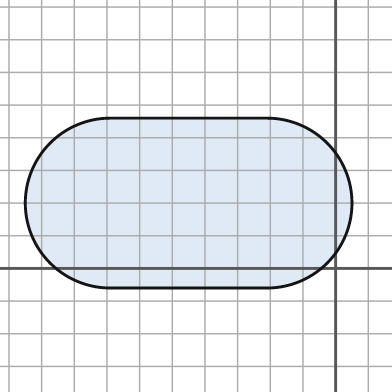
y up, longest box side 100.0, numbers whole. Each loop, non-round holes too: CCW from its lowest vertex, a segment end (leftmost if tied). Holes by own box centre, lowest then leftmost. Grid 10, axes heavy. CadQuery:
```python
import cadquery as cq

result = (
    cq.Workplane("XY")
    .moveTo(-69.0, -6.0)
    .lineTo(-21.0, -6.0)
    .threePointArc((5.0, 20.0), (-21.0, 46.0))
    .lineTo(-69.0, 46.0)
    .threePointArc((-95.0, 20.0), (-69.0, -6.0))
    .close()
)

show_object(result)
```